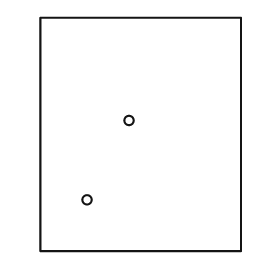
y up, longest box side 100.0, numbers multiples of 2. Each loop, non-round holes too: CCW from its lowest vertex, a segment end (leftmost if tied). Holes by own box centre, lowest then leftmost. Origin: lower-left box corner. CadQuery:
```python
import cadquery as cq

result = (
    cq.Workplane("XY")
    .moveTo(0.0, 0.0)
    .lineTo(86.0, 0.0)
    .lineTo(86.0, 100.0)
    .lineTo(0.0, 100.0)
    .close()
    .moveTo(20.0, 22.0)
    .circle(2.0)
    .moveTo(38.0, 56.0)
    .circle(2.0)
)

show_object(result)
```